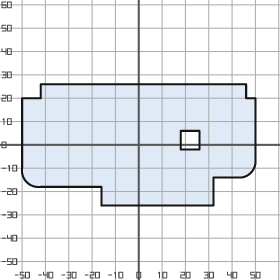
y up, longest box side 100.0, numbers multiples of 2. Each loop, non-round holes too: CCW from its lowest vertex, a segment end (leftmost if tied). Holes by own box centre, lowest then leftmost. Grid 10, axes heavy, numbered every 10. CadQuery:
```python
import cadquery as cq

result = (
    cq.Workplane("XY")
    .moveTo(-16.0, -26.0)
    .lineTo(32.0, -26.0)
    .lineTo(32.0, -14.0)
    .lineTo(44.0, -14.0)
    .threePointArc((48.0, -12.0), (50.0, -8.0))
    .lineTo(50.0, 20.0)
    .lineTo(46.0, 20.0)
    .lineTo(46.0, 26.0)
    .lineTo(-42.0, 26.0)
    .lineTo(-42.0, 20.0)
    .lineTo(-50.0, 20.0)
    .lineTo(-50.0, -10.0)
    .threePointArc((-48.0, -16.0), (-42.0, -18.0))
    .lineTo(-16.0, -18.0)
    .close()
    .moveTo(18.0, -2.0)
    .lineTo(26.0, -2.0)
    .lineTo(26.0, 6.0)
    .lineTo(18.0, 6.0)
    .close()
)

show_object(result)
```